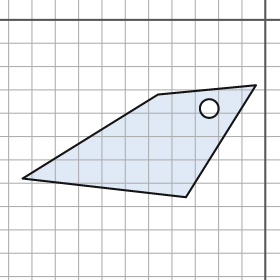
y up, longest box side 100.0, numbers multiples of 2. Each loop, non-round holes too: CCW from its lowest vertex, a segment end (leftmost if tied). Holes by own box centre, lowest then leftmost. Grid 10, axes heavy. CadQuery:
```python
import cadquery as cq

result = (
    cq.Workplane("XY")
    .moveTo(-34.0, -76.0)
    .lineTo(-4.0, -28.0)
    .lineTo(-46.0, -32.0)
    .lineTo(-104.0, -68.0)
    .close()
    .moveTo(-24.0, -38.0)
    .circle(4.0)
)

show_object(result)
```